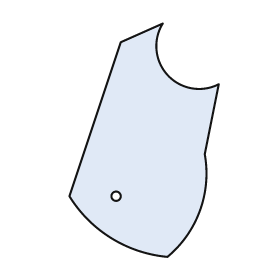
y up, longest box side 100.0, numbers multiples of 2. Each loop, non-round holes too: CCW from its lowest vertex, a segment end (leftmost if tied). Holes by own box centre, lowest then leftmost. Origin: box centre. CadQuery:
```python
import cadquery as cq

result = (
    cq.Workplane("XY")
    .moveTo(10.0, -50.0)
    .threePointArc((24.0, -30.0), (26.0, -6.0))
    .lineTo(32.0, 24.0)
    .threePointArc((10.0, 28.0), (8.0, 50.0))
    .lineTo(-10.0, 42.0)
    .lineTo(-32.0, -24.0)
    .threePointArc((-14.0, -42.0), (10.0, -50.0))
    .close()
    .moveTo(-12.0, -24.0)
    .circle(2.0)
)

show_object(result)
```